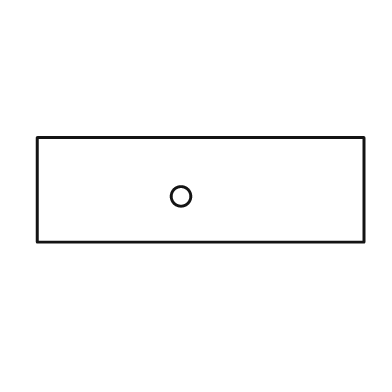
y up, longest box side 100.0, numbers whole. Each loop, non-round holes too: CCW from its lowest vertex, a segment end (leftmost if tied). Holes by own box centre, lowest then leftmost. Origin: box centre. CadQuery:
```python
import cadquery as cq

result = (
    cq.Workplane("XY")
    .moveTo(-50.0, -16.0)
    .lineTo(50.0, -16.0)
    .lineTo(50.0, 16.0)
    .lineTo(-50.0, 16.0)
    .close()
    .moveTo(-6.0, -2.0)
    .circle(3.0)
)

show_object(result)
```